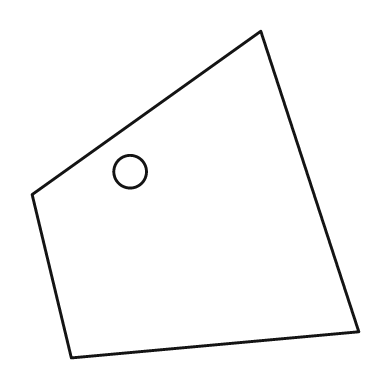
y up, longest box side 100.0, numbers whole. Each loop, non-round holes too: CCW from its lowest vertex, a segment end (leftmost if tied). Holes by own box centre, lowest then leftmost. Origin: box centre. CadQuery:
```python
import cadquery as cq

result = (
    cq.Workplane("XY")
    .moveTo(-38.0, -50.0)
    .lineTo(50.0, -42.0)
    .lineTo(20.0, 50.0)
    .lineTo(-50.0, 0.0)
    .close()
    .moveTo(-20.0, 7.0)
    .circle(5.0)
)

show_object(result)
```